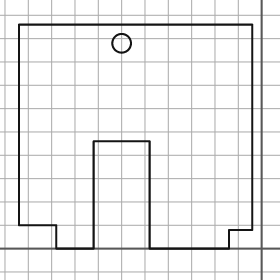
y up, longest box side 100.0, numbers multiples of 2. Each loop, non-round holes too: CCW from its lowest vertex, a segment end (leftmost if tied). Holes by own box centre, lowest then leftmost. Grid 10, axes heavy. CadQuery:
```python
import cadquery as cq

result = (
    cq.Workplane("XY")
    .moveTo(-88.0, 0.0)
    .lineTo(-72.0, 0.0)
    .lineTo(-72.0, 46.0)
    .lineTo(-48.0, 46.0)
    .lineTo(-48.0, 0.0)
    .lineTo(-14.0, 0.0)
    .lineTo(-14.0, 8.0)
    .lineTo(-4.0, 8.0)
    .lineTo(-4.0, 96.0)
    .lineTo(-104.0, 96.0)
    .lineTo(-104.0, 10.0)
    .lineTo(-88.0, 10.0)
    .close()
    .moveTo(-60.0, 88.0)
    .circle(4.0)
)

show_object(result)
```